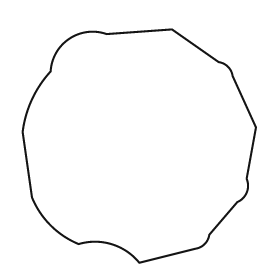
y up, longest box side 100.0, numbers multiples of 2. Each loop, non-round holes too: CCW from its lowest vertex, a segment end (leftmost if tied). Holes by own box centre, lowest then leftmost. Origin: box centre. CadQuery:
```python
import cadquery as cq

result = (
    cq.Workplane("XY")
    .moveTo(0.0, -50.0)
    .lineTo(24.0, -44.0)
    .threePointArc((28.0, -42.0), (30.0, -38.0))
    .lineTo(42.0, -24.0)
    .threePointArc((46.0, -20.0), (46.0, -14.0))
    .lineTo(50.0, 8.0)
    .lineTo(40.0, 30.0)
    .threePointArc((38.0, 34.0), (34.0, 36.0))
    .lineTo(14.0, 50.0)
    .lineTo(-14.0, 48.0)
    .threePointArc((-30.0, 46.0), (-38.0, 32.0))
    .threePointArc((-46.0, 20.0), (-50.0, 6.0))
    .lineTo(-46.0, -22.0)
    .threePointArc((-38.0, -34.0), (-26.0, -42.0))
    .threePointArc((-12.0, -42.0), (0.0, -50.0))
    .close()
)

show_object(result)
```